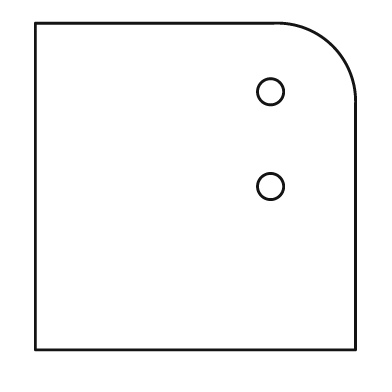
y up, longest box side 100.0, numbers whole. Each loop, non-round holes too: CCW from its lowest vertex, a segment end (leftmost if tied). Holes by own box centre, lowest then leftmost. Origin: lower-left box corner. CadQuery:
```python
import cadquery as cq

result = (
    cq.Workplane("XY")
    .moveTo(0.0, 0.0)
    .lineTo(98.0, 0.0)
    .lineTo(98.0, 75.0)
    .threePointArc((91.0, 93.0), (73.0, 100.0))
    .lineTo(0.0, 100.0)
    .close()
    .moveTo(72.0, 50.0)
    .circle(4.0)
    .moveTo(72.0, 79.0)
    .circle(4.0)
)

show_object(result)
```